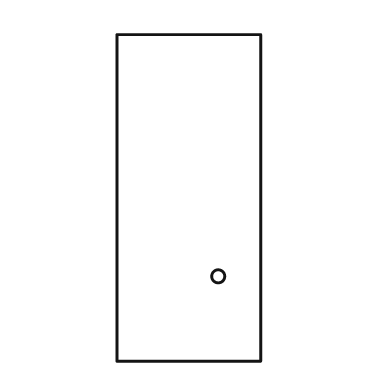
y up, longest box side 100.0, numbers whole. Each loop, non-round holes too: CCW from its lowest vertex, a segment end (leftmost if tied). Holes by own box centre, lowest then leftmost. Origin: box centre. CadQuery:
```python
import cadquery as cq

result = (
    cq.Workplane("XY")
    .moveTo(-22.0, -50.0)
    .lineTo(22.0, -50.0)
    .lineTo(22.0, 50.0)
    .lineTo(-22.0, 50.0)
    .close()
    .moveTo(9.0, -24.0)
    .circle(2.0)
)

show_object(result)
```